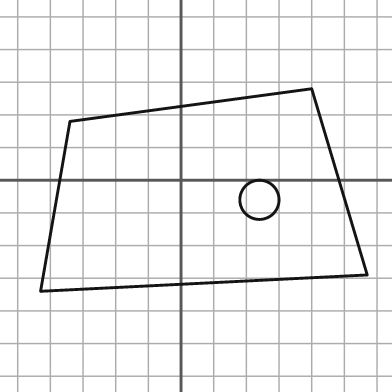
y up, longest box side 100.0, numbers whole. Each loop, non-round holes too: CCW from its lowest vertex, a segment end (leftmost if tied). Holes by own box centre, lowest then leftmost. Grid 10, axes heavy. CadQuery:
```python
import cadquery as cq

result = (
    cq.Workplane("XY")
    .moveTo(-43.0, -34.0)
    .lineTo(57.0, -29.0)
    .lineTo(40.0, 28.0)
    .lineTo(-34.0, 18.0)
    .close()
    .moveTo(24.0, -6.0)
    .circle(6.0)
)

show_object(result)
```